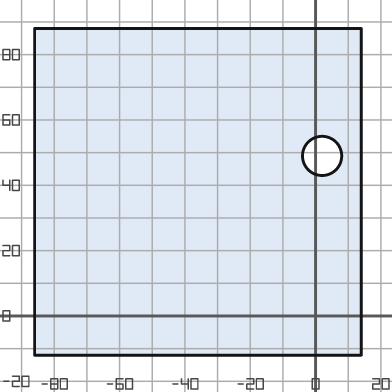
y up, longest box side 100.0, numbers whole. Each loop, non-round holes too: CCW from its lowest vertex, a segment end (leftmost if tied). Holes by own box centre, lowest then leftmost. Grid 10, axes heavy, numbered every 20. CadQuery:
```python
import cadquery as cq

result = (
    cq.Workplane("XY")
    .moveTo(-86.0, -12.0)
    .lineTo(14.0, -12.0)
    .lineTo(14.0, 88.0)
    .lineTo(-86.0, 88.0)
    .close()
    .moveTo(2.0, 49.0)
    .circle(6.0)
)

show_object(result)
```